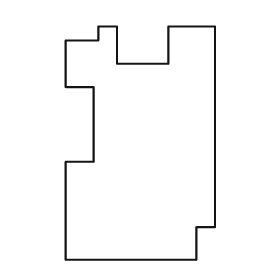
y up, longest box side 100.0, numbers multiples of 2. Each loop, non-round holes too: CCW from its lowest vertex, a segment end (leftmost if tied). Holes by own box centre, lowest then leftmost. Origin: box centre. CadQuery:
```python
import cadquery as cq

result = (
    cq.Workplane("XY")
    .moveTo(-32.0, -50.0)
    .lineTo(24.0, -50.0)
    .lineTo(24.0, -36.0)
    .lineTo(32.0, -36.0)
    .lineTo(32.0, 50.0)
    .lineTo(12.0, 50.0)
    .lineTo(12.0, 34.0)
    .lineTo(-10.0, 34.0)
    .lineTo(-10.0, 50.0)
    .lineTo(-18.0, 50.0)
    .lineTo(-18.0, 44.0)
    .lineTo(-32.0, 44.0)
    .lineTo(-32.0, 24.0)
    .lineTo(-20.0, 24.0)
    .lineTo(-20.0, -8.0)
    .lineTo(-32.0, -8.0)
    .close()
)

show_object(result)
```